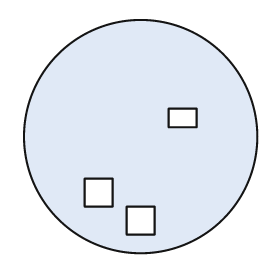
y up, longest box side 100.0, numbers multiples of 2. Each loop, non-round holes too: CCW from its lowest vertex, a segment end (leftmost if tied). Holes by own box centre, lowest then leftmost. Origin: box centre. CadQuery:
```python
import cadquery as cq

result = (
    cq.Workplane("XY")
    .moveTo(0.0, 0.0)
    .circle(50.0)
    .moveTo(-6.0, -42.0)
    .lineTo(6.0, -42.0)
    .lineTo(6.0, -30.0)
    .lineTo(-6.0, -30.0)
    .close()
    .moveTo(-24.0, -30.0)
    .lineTo(-12.0, -30.0)
    .lineTo(-12.0, -18.0)
    .lineTo(-24.0, -18.0)
    .close()
    .moveTo(12.0, 4.0)
    .lineTo(24.0, 4.0)
    .lineTo(24.0, 12.0)
    .lineTo(12.0, 12.0)
    .close()
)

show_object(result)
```